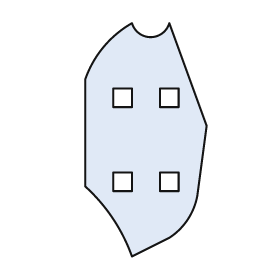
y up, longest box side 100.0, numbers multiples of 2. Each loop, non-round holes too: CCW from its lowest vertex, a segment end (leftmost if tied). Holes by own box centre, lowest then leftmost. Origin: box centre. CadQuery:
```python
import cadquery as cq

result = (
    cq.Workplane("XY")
    .moveTo(-6.0, -50.0)
    .lineTo(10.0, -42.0)
    .threePointArc((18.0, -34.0), (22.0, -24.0))
    .lineTo(26.0, 6.0)
    .lineTo(10.0, 50.0)
    .threePointArc((2.0, 44.0), (-6.0, 50.0))
    .threePointArc((-18.0, 40.0), (-26.0, 26.0))
    .lineTo(-26.0, -20.0)
    .threePointArc((-14.0, -34.0), (-6.0, -50.0))
    .close()
    .moveTo(-14.0, -22.0)
    .lineTo(-6.0, -22.0)
    .lineTo(-6.0, -14.0)
    .lineTo(-14.0, -14.0)
    .close()
    .moveTo(6.0, -22.0)
    .lineTo(14.0, -22.0)
    .lineTo(14.0, -14.0)
    .lineTo(6.0, -14.0)
    .close()
    .moveTo(-14.0, 14.0)
    .lineTo(-6.0, 14.0)
    .lineTo(-6.0, 22.0)
    .lineTo(-14.0, 22.0)
    .close()
    .moveTo(6.0, 14.0)
    .lineTo(14.0, 14.0)
    .lineTo(14.0, 22.0)
    .lineTo(6.0, 22.0)
    .close()
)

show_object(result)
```